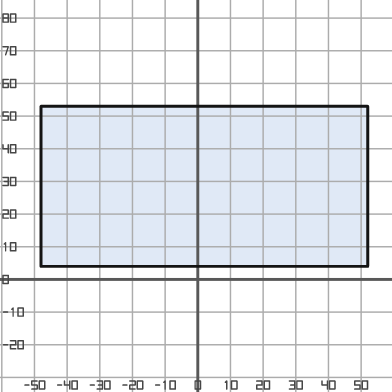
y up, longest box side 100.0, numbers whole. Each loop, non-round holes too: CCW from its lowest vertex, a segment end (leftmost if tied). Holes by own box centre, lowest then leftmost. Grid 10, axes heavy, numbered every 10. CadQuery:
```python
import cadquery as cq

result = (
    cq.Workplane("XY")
    .moveTo(-48.0, 4.0)
    .lineTo(52.0, 4.0)
    .lineTo(52.0, 53.0)
    .lineTo(-48.0, 53.0)
    .close()
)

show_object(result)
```